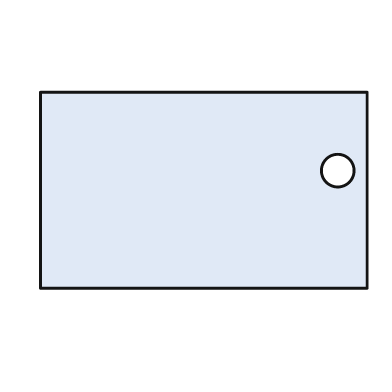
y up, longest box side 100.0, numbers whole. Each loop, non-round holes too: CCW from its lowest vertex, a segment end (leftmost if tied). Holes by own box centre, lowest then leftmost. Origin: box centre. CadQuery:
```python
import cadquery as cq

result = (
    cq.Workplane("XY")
    .moveTo(-50.0, -30.0)
    .lineTo(50.0, -30.0)
    .lineTo(50.0, 30.0)
    .lineTo(-50.0, 30.0)
    .close()
    .moveTo(41.0, 6.0)
    .circle(5.0)
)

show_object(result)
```